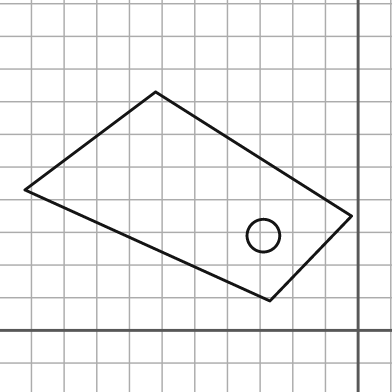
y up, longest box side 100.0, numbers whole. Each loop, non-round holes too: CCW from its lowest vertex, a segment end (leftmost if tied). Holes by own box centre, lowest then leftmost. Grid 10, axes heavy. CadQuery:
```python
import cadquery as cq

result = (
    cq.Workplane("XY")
    .moveTo(-27.0, 9.0)
    .lineTo(-2.0, 35.0)
    .lineTo(-62.0, 73.0)
    .lineTo(-102.0, 43.0)
    .close()
    .moveTo(-29.0, 29.0)
    .circle(5.0)
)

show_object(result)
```